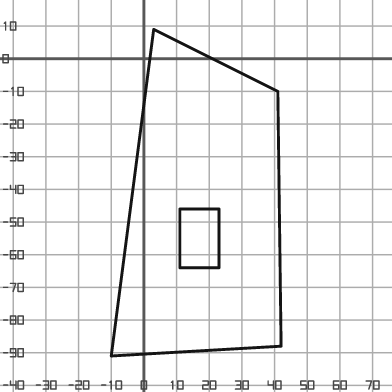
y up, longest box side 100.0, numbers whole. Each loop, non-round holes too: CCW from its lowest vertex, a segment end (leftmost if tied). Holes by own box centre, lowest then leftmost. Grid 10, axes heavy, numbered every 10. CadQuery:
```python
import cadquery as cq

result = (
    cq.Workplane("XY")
    .moveTo(-10.0, -91.0)
    .lineTo(42.0, -88.0)
    .lineTo(41.0, -10.0)
    .lineTo(3.0, 9.0)
    .close()
    .moveTo(11.0, -64.0)
    .lineTo(23.0, -64.0)
    .lineTo(23.0, -46.0)
    .lineTo(11.0, -46.0)
    .close()
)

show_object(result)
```